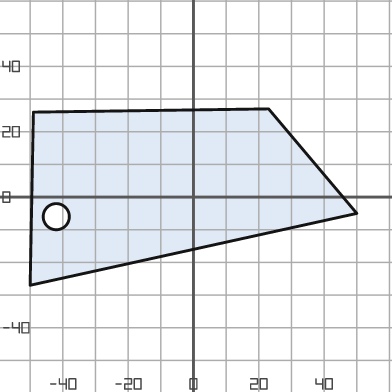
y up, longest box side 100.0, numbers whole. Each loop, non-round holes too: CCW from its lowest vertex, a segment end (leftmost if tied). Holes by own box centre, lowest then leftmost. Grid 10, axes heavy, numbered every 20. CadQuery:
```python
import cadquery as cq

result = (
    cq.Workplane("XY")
    .moveTo(-50.0, -27.0)
    .lineTo(50.0, -5.0)
    .lineTo(23.0, 27.0)
    .lineTo(-49.0, 26.0)
    .close()
    .moveTo(-42.0, -6.0)
    .circle(4.0)
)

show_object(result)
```